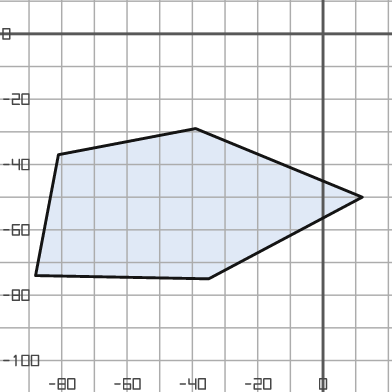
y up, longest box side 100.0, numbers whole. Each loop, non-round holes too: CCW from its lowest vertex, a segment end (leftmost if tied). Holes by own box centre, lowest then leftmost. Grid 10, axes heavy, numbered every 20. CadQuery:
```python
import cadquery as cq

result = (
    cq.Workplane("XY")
    .moveTo(-35.0, -75.0)
    .lineTo(12.0, -50.0)
    .lineTo(-39.0, -29.0)
    .lineTo(-81.0, -37.0)
    .lineTo(-88.0, -74.0)
    .close()
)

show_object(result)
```